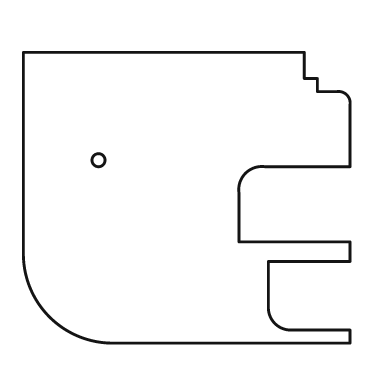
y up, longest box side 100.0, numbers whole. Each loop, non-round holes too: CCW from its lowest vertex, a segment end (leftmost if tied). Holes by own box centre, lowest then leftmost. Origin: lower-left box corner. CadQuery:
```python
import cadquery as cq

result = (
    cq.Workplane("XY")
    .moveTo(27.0, 0.0)
    .lineTo(100.0, 0.0)
    .lineTo(100.0, 4.0)
    .lineTo(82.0, 4.0)
    .threePointArc((77.0, 6.0), (75.0, 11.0))
    .lineTo(75.0, 25.0)
    .lineTo(100.0, 25.0)
    .lineTo(100.0, 31.0)
    .lineTo(66.0, 31.0)
    .lineTo(66.0, 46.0)
    .threePointArc((68.0, 52.0), (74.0, 54.0))
    .lineTo(100.0, 54.0)
    .lineTo(100.0, 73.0)
    .threePointArc((99.0, 76.0), (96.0, 77.0))
    .lineTo(90.0, 77.0)
    .lineTo(90.0, 81.0)
    .lineTo(86.0, 81.0)
    .lineTo(86.0, 89.0)
    .lineTo(0.0, 89.0)
    .lineTo(0.0, 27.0)
    .threePointArc((8.0, 8.0), (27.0, 0.0))
    .close()
    .moveTo(23.0, 56.0)
    .circle(2.0)
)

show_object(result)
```